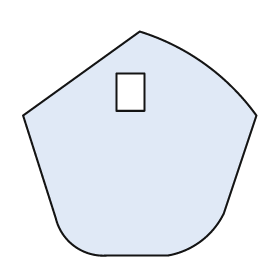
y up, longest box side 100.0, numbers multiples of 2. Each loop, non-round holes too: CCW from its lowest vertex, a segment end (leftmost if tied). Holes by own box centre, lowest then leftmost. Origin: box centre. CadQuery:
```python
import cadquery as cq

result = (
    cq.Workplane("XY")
    .moveTo(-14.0, -48.0)
    .lineTo(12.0, -48.0)
    .threePointArc((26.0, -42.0), (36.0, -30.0))
    .lineTo(50.0, 12.0)
    .threePointArc((28.0, 34.0), (0.0, 48.0))
    .lineTo(-50.0, 12.0)
    .lineTo(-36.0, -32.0)
    .threePointArc((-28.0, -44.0), (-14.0, -48.0))
    .close()
    .moveTo(-10.0, 14.0)
    .lineTo(2.0, 14.0)
    .lineTo(2.0, 30.0)
    .lineTo(-10.0, 30.0)
    .close()
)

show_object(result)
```